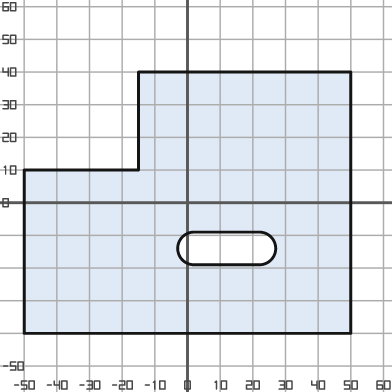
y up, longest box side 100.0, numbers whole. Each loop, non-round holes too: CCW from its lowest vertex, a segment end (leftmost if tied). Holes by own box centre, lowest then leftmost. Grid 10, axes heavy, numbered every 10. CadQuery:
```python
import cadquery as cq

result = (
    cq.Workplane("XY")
    .moveTo(-50.0, -40.0)
    .lineTo(50.0, -40.0)
    .lineTo(50.0, 40.0)
    .lineTo(-15.0, 40.0)
    .lineTo(-15.0, 10.0)
    .lineTo(-50.0, 10.0)
    .close()
    .moveTo(2.0, -19.0)
    .lineTo(22.0, -19.0)
    .threePointArc((27.0, -14.0), (22.0, -9.0))
    .lineTo(2.0, -9.0)
    .threePointArc((-3.0, -14.0), (2.0, -19.0))
    .close()
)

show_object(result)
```